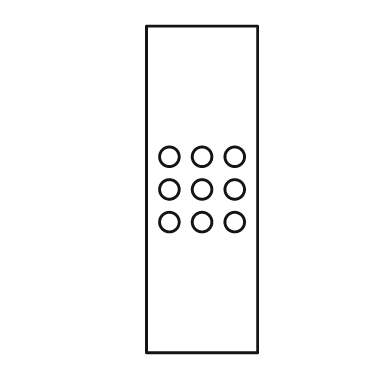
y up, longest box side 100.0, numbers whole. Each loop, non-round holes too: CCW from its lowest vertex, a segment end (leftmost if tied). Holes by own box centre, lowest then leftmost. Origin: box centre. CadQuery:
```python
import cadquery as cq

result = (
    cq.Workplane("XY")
    .moveTo(-17.0, -50.0)
    .lineTo(17.0, -50.0)
    .lineTo(17.0, 50.0)
    .lineTo(-17.0, 50.0)
    .close()
    .moveTo(-10.0, -10.0)
    .circle(3.0)
    .moveTo(0.0, -10.0)
    .circle(3.0)
    .moveTo(10.0, -10.0)
    .circle(3.0)
    .moveTo(-10.0, 0.0)
    .circle(3.0)
    .moveTo(0.0, 0.0)
    .circle(3.0)
    .moveTo(10.0, 0.0)
    .circle(3.0)
    .moveTo(-10.0, 10.0)
    .circle(3.0)
    .moveTo(0.0, 10.0)
    .circle(3.0)
    .moveTo(10.0, 10.0)
    .circle(3.0)
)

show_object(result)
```